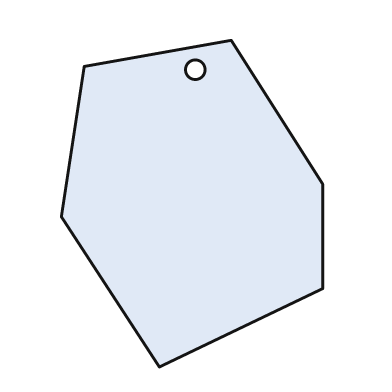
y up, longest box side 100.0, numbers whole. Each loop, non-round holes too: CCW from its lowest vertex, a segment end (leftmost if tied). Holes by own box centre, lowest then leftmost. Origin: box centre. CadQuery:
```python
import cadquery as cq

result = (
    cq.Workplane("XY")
    .moveTo(-10.0, -50.0)
    .lineTo(40.0, -26.0)
    .lineTo(40.0, 6.0)
    .lineTo(12.0, 50.0)
    .lineTo(-33.0, 42.0)
    .lineTo(-40.0, -4.0)
    .close()
    .moveTo(1.0, 41.0)
    .circle(3.0)
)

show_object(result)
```